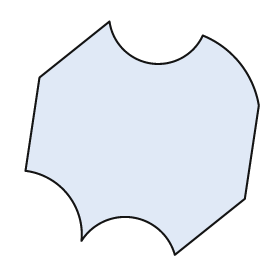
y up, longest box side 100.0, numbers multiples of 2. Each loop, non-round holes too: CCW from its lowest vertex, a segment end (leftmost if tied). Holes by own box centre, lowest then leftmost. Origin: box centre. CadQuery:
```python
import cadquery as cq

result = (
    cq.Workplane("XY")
    .moveTo(14.0, -50.0)
    .lineTo(44.0, -26.0)
    .lineTo(50.0, 14.0)
    .threePointArc((42.0, 32.0), (26.0, 44.0))
    .threePointArc((4.0, 32.0), (-14.0, 50.0))
    .lineTo(-44.0, 26.0)
    .lineTo(-50.0, -14.0)
    .threePointArc((-32.0, -24.0), (-26.0, -44.0))
    .threePointArc((-4.0, -34.0), (14.0, -50.0))
    .close()
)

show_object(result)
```